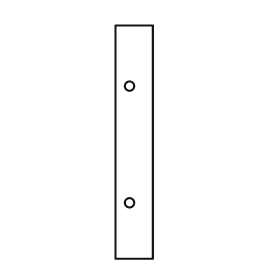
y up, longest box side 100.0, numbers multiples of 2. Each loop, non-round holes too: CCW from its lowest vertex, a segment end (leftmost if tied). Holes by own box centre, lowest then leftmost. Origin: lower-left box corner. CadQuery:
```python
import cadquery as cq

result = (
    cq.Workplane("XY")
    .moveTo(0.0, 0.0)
    .lineTo(16.0, 0.0)
    .lineTo(16.0, 100.0)
    .lineTo(0.0, 100.0)
    .close()
    .moveTo(6.0, 24.0)
    .circle(2.0)
    .moveTo(6.0, 74.0)
    .circle(2.0)
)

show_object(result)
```